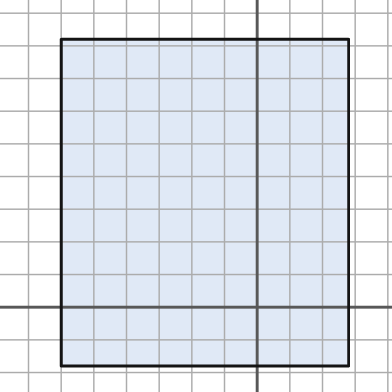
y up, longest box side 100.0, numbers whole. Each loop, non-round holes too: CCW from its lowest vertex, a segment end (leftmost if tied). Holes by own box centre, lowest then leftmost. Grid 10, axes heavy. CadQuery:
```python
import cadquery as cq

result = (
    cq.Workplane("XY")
    .moveTo(-60.0, -18.0)
    .lineTo(28.0, -18.0)
    .lineTo(28.0, 82.0)
    .lineTo(-60.0, 82.0)
    .close()
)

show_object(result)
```